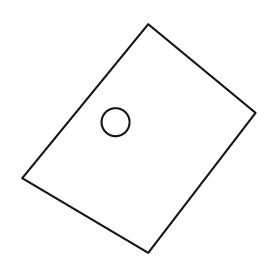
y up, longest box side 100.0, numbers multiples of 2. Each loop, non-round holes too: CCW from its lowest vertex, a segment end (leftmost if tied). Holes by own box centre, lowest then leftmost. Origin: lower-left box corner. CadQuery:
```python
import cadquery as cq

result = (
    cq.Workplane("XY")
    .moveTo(54.0, 0.0)
    .lineTo(100.0, 60.0)
    .lineTo(54.0, 98.0)
    .lineTo(0.0, 32.0)
    .close()
    .moveTo(40.0, 56.0)
    .circle(6.0)
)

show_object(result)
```